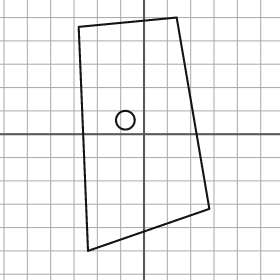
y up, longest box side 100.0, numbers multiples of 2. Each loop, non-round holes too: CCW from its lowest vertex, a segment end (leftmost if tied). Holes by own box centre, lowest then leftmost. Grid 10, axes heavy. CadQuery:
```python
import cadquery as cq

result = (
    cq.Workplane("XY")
    .moveTo(-24.0, -50.0)
    .lineTo(28.0, -32.0)
    .lineTo(14.0, 50.0)
    .lineTo(-28.0, 46.0)
    .close()
    .moveTo(-8.0, 6.0)
    .circle(4.0)
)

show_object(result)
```